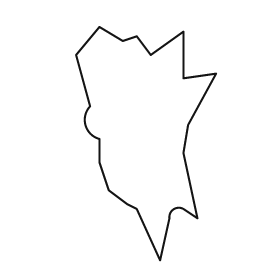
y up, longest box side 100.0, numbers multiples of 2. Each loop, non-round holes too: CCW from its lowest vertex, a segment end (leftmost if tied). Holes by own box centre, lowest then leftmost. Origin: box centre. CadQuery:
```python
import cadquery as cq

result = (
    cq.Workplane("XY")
    .moveTo(6.0, -50.0)
    .lineTo(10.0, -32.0)
    .threePointArc((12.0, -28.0), (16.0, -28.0))
    .lineTo(22.0, -32.0)
    .lineTo(16.0, -4.0)
    .lineTo(18.0, 8.0)
    .lineTo(30.0, 30.0)
    .lineTo(16.0, 28.0)
    .lineTo(16.0, 48.0)
    .lineTo(2.0, 38.0)
    .lineTo(-4.0, 46.0)
    .lineTo(-10.0, 44.0)
    .lineTo(-20.0, 50.0)
    .lineTo(-30.0, 38.0)
    .lineTo(-24.0, 16.0)
    .threePointArc((-26.0, 8.0), (-20.0, 2.0))
    .lineTo(-20.0, -8.0)
    .lineTo(-16.0, -20.0)
    .lineTo(-8.0, -26.0)
    .lineTo(-4.0, -28.0)
    .close()
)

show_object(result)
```